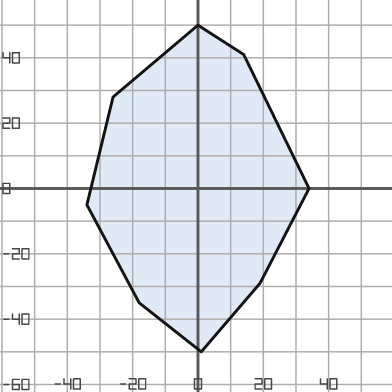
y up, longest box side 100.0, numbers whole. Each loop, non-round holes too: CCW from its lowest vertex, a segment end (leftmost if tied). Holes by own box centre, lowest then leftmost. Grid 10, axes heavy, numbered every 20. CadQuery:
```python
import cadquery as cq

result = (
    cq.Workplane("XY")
    .moveTo(1.0, -50.0)
    .lineTo(19.0, -29.0)
    .lineTo(34.0, 0.0)
    .lineTo(14.0, 41.0)
    .lineTo(0.0, 50.0)
    .lineTo(-26.0, 28.0)
    .lineTo(-34.0, -5.0)
    .lineTo(-18.0, -35.0)
    .close()
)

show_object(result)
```